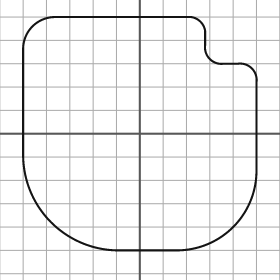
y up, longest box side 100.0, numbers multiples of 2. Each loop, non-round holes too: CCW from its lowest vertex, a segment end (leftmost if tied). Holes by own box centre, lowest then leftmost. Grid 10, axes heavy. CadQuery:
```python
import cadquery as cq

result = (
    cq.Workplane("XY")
    .moveTo(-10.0, -50.0)
    .lineTo(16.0, -50.0)
    .threePointArc((40.0, -40.0), (50.0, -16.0))
    .lineTo(50.0, 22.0)
    .threePointArc((48.0, 28.0), (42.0, 30.0))
    .lineTo(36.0, 30.0)
    .threePointArc((30.0, 32.0), (28.0, 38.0))
    .lineTo(28.0, 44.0)
    .threePointArc((26.0, 48.0), (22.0, 50.0))
    .lineTo(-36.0, 50.0)
    .threePointArc((-46.0, 46.0), (-50.0, 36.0))
    .lineTo(-50.0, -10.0)
    .threePointArc((-38.0, -38.0), (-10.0, -50.0))
    .close()
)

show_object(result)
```